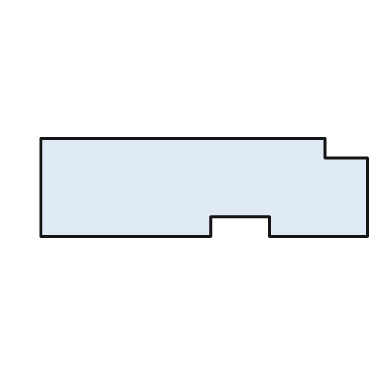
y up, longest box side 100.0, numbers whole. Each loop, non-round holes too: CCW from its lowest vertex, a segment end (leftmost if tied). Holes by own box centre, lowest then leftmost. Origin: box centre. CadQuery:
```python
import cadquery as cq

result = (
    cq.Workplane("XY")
    .moveTo(-50.0, -15.0)
    .lineTo(2.0, -15.0)
    .lineTo(2.0, -9.0)
    .lineTo(20.0, -9.0)
    .lineTo(20.0, -15.0)
    .lineTo(50.0, -15.0)
    .lineTo(50.0, 9.0)
    .lineTo(37.0, 9.0)
    .lineTo(37.0, 15.0)
    .lineTo(-50.0, 15.0)
    .close()
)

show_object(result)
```